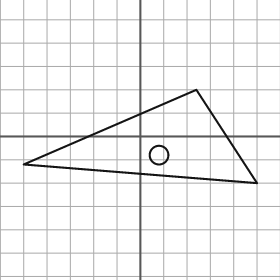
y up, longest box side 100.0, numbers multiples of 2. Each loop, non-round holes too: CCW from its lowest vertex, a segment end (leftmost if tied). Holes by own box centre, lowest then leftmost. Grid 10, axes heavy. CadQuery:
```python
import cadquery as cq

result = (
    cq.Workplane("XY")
    .moveTo(50.0, -20.0)
    .lineTo(24.0, 20.0)
    .lineTo(-50.0, -12.0)
    .close()
    .moveTo(8.0, -8.0)
    .circle(4.0)
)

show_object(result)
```